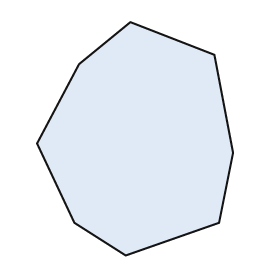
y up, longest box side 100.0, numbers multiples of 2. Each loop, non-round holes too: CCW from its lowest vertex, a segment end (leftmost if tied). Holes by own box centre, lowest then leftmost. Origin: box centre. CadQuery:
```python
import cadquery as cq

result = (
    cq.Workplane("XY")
    .moveTo(-4.0, -50.0)
    .lineTo(36.0, -36.0)
    .lineTo(42.0, -6.0)
    .lineTo(34.0, 36.0)
    .lineTo(-2.0, 50.0)
    .lineTo(-24.0, 32.0)
    .lineTo(-42.0, -2.0)
    .lineTo(-26.0, -36.0)
    .close()
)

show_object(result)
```